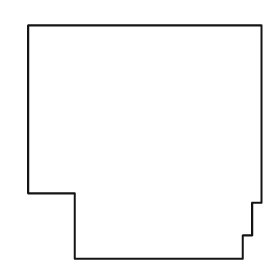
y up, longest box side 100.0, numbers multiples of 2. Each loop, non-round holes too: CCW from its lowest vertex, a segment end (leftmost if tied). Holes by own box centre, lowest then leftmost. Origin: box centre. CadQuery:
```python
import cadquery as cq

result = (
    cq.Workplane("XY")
    .moveTo(-30.0, -50.0)
    .lineTo(42.0, -50.0)
    .lineTo(42.0, -40.0)
    .lineTo(46.0, -40.0)
    .lineTo(46.0, -26.0)
    .lineTo(50.0, -26.0)
    .lineTo(50.0, 50.0)
    .lineTo(-50.0, 50.0)
    .lineTo(-50.0, -22.0)
    .lineTo(-30.0, -22.0)
    .close()
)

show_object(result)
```